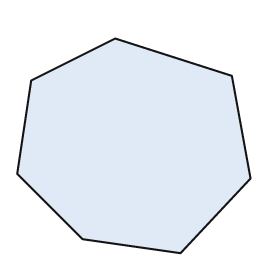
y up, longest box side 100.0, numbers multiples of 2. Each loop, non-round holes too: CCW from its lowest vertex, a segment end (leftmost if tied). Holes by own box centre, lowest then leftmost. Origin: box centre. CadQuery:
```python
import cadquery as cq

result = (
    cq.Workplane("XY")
    .moveTo(20.0, -46.0)
    .lineTo(50.0, -14.0)
    .lineTo(42.0, 30.0)
    .lineTo(-8.0, 46.0)
    .lineTo(-44.0, 28.0)
    .lineTo(-50.0, -12.0)
    .lineTo(-22.0, -40.0)
    .close()
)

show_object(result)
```